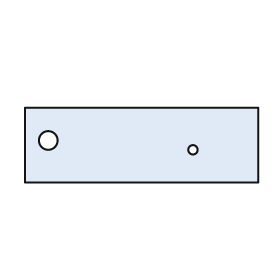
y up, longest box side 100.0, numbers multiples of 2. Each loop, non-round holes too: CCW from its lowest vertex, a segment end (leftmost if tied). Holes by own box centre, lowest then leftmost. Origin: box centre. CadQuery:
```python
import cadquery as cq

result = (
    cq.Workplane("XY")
    .moveTo(-50.0, -16.0)
    .lineTo(50.0, -16.0)
    .lineTo(50.0, 16.0)
    .lineTo(-50.0, 16.0)
    .close()
    .moveTo(22.0, -2.0)
    .circle(2.0)
    .moveTo(-40.0, 2.0)
    .circle(4.0)
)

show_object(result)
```